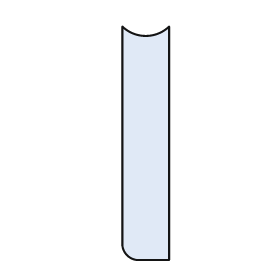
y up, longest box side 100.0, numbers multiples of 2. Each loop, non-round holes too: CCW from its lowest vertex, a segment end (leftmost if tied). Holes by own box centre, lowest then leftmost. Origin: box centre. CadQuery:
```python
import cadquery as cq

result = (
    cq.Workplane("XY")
    .moveTo(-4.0, -50.0)
    .lineTo(10.0, -50.0)
    .lineTo(10.0, 50.0)
    .threePointArc((0.0, 46.0), (-10.0, 50.0))
    .lineTo(-10.0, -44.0)
    .threePointArc((-8.0, -48.0), (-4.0, -50.0))
    .close()
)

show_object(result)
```